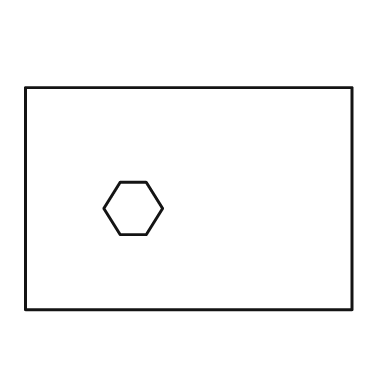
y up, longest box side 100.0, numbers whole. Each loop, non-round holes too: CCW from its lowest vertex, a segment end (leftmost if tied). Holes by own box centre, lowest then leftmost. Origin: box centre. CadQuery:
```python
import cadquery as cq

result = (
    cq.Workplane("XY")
    .moveTo(-50.0, -34.0)
    .lineTo(50.0, -34.0)
    .lineTo(50.0, 34.0)
    .lineTo(-50.0, 34.0)
    .close()
    .moveTo(-21.0, -11.0)
    .lineTo(-13.0, -11.0)
    .lineTo(-8.0, -3.0)
    .lineTo(-13.0, 5.0)
    .lineTo(-21.0, 5.0)
    .lineTo(-26.0, -3.0)
    .close()
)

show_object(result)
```